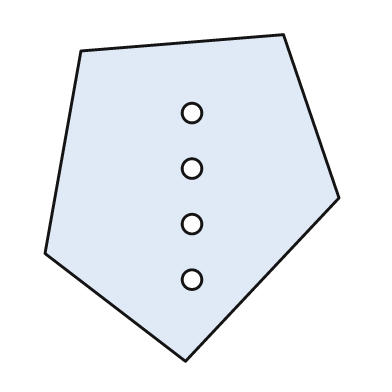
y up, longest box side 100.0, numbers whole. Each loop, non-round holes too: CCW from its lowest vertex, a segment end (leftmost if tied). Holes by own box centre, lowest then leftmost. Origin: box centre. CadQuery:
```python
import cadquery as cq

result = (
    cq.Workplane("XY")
    .moveTo(-2.0, -50.0)
    .lineTo(45.0, 0.0)
    .lineTo(28.0, 50.0)
    .lineTo(-34.0, 45.0)
    .lineTo(-45.0, -17.0)
    .close()
    .moveTo(0.0, -25.0)
    .circle(3.0)
    .moveTo(0.0, -8.0)
    .circle(3.0)
    .moveTo(0.0, 9.0)
    .circle(3.0)
    .moveTo(0.0, 26.0)
    .circle(3.0)
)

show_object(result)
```